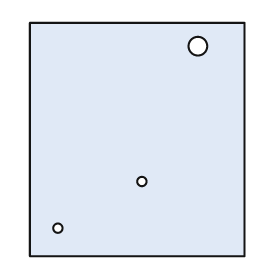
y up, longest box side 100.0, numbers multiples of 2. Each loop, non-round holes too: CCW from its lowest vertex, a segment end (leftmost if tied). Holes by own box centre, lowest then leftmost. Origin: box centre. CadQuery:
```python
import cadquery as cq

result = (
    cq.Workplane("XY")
    .moveTo(-46.0, -50.0)
    .lineTo(46.0, -50.0)
    .lineTo(46.0, 50.0)
    .lineTo(-46.0, 50.0)
    .close()
    .moveTo(-34.0, -38.0)
    .circle(2.0)
    .moveTo(2.0, -18.0)
    .circle(2.0)
    .moveTo(26.0, 40.0)
    .circle(4.0)
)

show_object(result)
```